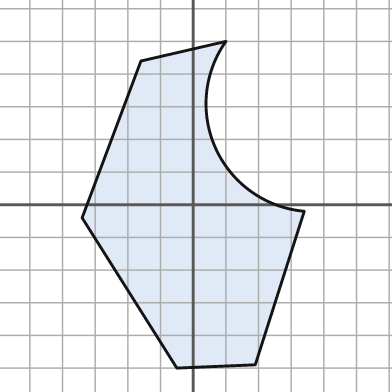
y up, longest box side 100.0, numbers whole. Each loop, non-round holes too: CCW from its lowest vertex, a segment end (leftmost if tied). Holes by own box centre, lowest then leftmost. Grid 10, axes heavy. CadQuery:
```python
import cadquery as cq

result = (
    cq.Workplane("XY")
    .moveTo(-5.0, -50.0)
    .lineTo(19.0, -49.0)
    .lineTo(34.0, -2.0)
    .threePointArc((7.0, 17.0), (10.0, 50.0))
    .lineTo(-16.0, 44.0)
    .lineTo(-34.0, -4.0)
    .close()
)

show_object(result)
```